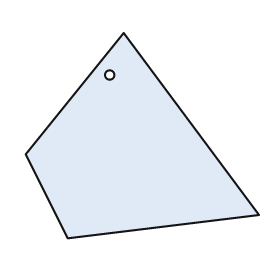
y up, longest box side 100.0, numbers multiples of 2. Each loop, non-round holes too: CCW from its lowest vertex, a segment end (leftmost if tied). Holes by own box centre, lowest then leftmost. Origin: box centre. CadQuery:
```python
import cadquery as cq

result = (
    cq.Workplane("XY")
    .moveTo(-32.0, -44.0)
    .lineTo(50.0, -34.0)
    .lineTo(-8.0, 44.0)
    .lineTo(-50.0, -8.0)
    .close()
    .moveTo(-14.0, 26.0)
    .circle(2.0)
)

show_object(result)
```